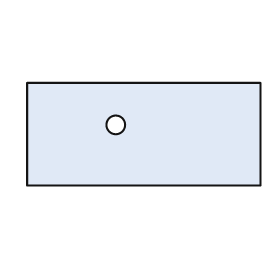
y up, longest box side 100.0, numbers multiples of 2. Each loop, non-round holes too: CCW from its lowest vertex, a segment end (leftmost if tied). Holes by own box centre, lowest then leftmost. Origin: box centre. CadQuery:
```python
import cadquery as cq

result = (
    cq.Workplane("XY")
    .moveTo(-50.0, -22.0)
    .lineTo(50.0, -22.0)
    .lineTo(50.0, 22.0)
    .lineTo(-50.0, 22.0)
    .close()
    .moveTo(-12.0, 4.0)
    .circle(4.0)
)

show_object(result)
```